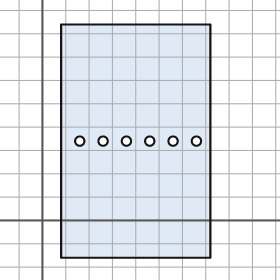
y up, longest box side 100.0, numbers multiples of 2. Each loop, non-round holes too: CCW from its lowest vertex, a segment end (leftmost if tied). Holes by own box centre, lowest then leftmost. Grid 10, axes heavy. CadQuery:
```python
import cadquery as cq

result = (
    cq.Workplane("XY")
    .moveTo(8.0, -16.0)
    .lineTo(72.0, -16.0)
    .lineTo(72.0, 84.0)
    .lineTo(8.0, 84.0)
    .close()
    .moveTo(16.0, 34.0)
    .circle(2.0)
    .moveTo(26.0, 34.0)
    .circle(2.0)
    .moveTo(36.0, 34.0)
    .circle(2.0)
    .moveTo(46.0, 34.0)
    .circle(2.0)
    .moveTo(56.0, 34.0)
    .circle(2.0)
    .moveTo(66.0, 34.0)
    .circle(2.0)
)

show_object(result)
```